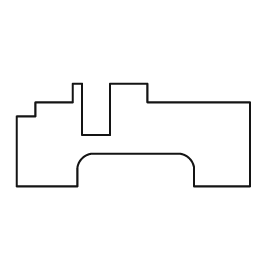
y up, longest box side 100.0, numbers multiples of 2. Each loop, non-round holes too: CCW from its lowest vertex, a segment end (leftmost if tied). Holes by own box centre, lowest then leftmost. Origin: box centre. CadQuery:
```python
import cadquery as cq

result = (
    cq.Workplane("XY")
    .moveTo(-50.0, -22.0)
    .lineTo(-24.0, -22.0)
    .lineTo(-24.0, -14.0)
    .threePointArc((-22.0, -10.0), (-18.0, -8.0))
    .lineTo(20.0, -8.0)
    .threePointArc((24.0, -10.0), (26.0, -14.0))
    .lineTo(26.0, -22.0)
    .lineTo(50.0, -22.0)
    .lineTo(50.0, 14.0)
    .lineTo(6.0, 14.0)
    .lineTo(6.0, 22.0)
    .lineTo(-10.0, 22.0)
    .lineTo(-10.0, 0.0)
    .lineTo(-22.0, 0.0)
    .lineTo(-22.0, 22.0)
    .lineTo(-26.0, 22.0)
    .lineTo(-26.0, 14.0)
    .lineTo(-42.0, 14.0)
    .lineTo(-42.0, 8.0)
    .lineTo(-50.0, 8.0)
    .close()
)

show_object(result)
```